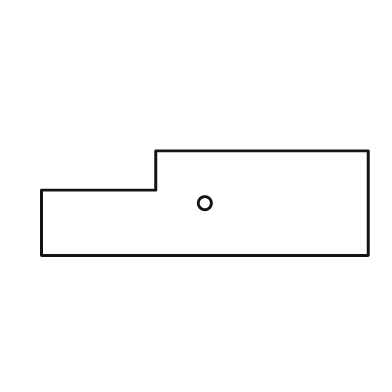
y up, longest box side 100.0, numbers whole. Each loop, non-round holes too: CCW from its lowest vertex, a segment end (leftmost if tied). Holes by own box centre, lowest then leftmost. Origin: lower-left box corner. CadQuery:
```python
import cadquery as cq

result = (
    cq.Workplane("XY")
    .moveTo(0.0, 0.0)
    .lineTo(100.0, 0.0)
    .lineTo(100.0, 32.0)
    .lineTo(35.0, 32.0)
    .lineTo(35.0, 20.0)
    .lineTo(0.0, 20.0)
    .close()
    .moveTo(50.0, 16.0)
    .circle(2.0)
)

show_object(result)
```